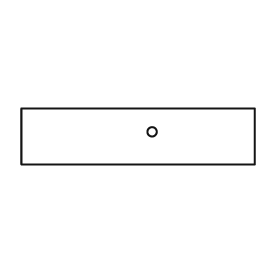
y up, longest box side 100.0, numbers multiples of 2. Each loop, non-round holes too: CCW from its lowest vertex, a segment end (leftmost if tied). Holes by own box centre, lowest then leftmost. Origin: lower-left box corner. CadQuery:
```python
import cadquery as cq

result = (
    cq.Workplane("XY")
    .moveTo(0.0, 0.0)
    .lineTo(100.0, 0.0)
    .lineTo(100.0, 24.0)
    .lineTo(0.0, 24.0)
    .close()
    .moveTo(56.0, 14.0)
    .circle(2.0)
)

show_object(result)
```